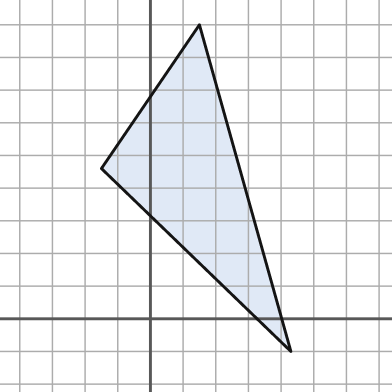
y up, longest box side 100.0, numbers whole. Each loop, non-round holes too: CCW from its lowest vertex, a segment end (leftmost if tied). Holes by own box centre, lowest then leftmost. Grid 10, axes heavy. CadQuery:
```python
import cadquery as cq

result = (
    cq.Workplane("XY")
    .moveTo(43.0, -10.0)
    .lineTo(15.0, 90.0)
    .lineTo(-15.0, 46.0)
    .close()
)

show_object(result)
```